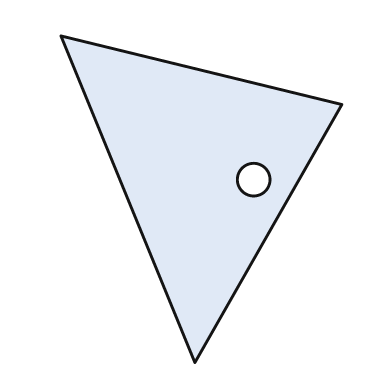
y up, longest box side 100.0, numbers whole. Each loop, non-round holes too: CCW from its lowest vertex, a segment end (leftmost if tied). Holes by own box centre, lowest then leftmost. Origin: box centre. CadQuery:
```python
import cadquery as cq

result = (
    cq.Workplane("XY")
    .moveTo(-2.0, -50.0)
    .lineTo(43.0, 29.0)
    .lineTo(-43.0, 50.0)
    .close()
    .moveTo(16.0, 6.0)
    .circle(5.0)
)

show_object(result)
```